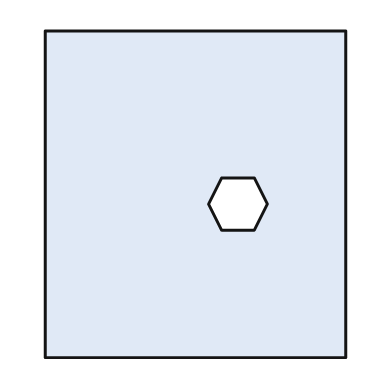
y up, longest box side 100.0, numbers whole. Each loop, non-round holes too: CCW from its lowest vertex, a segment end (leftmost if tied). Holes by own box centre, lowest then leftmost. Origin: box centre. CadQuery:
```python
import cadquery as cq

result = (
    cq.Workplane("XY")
    .moveTo(-46.0, -50.0)
    .lineTo(46.0, -50.0)
    .lineTo(46.0, 50.0)
    .lineTo(-46.0, 50.0)
    .close()
    .moveTo(8.0, -11.0)
    .lineTo(18.0, -11.0)
    .lineTo(22.0, -3.0)
    .lineTo(18.0, 5.0)
    .lineTo(8.0, 5.0)
    .lineTo(4.0, -3.0)
    .close()
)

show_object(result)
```